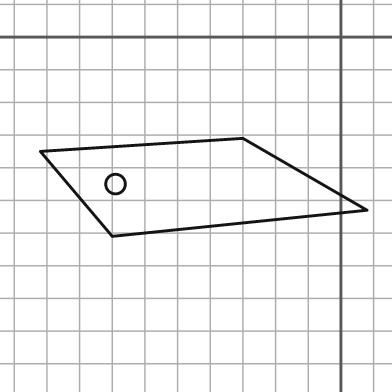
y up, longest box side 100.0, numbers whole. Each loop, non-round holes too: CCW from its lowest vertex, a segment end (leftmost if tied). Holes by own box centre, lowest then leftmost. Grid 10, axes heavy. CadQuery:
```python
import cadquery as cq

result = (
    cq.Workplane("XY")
    .moveTo(-70.0, -61.0)
    .lineTo(8.0, -53.0)
    .lineTo(-30.0, -31.0)
    .lineTo(-92.0, -35.0)
    .close()
    .moveTo(-69.0, -45.0)
    .circle(3.0)
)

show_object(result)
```